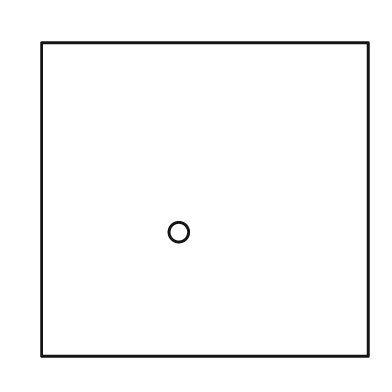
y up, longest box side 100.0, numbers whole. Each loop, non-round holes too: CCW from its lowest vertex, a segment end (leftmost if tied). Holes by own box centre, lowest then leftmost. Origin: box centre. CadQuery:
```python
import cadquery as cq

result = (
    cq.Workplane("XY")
    .moveTo(-50.0, -48.0)
    .lineTo(50.0, -48.0)
    .lineTo(50.0, 48.0)
    .lineTo(-50.0, 48.0)
    .close()
    .moveTo(-8.0, -10.0)
    .circle(3.0)
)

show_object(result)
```